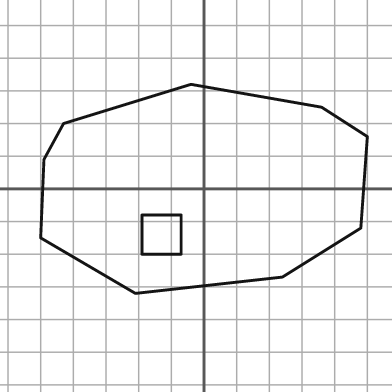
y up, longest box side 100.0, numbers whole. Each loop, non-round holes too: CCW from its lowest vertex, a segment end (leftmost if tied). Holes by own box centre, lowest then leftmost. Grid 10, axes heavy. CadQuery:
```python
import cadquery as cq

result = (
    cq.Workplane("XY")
    .moveTo(-21.0, -32.0)
    .lineTo(24.0, -27.0)
    .lineTo(48.0, -12.0)
    .lineTo(50.0, 16.0)
    .lineTo(36.0, 25.0)
    .lineTo(-4.0, 32.0)
    .lineTo(-43.0, 20.0)
    .lineTo(-49.0, 9.0)
    .lineTo(-50.0, -15.0)
    .close()
    .moveTo(-19.0, -20.0)
    .lineTo(-7.0, -20.0)
    .lineTo(-7.0, -8.0)
    .lineTo(-19.0, -8.0)
    .close()
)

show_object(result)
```